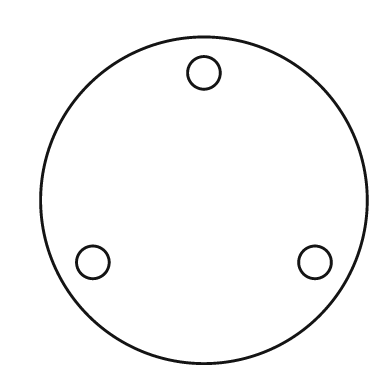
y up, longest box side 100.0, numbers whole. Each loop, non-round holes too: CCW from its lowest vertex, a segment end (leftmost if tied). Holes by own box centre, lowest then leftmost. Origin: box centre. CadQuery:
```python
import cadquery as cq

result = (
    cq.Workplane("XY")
    .moveTo(0.0, 0.0)
    .circle(50.0)
    .moveTo(-34.0, -19.0)
    .circle(5.0)
    .moveTo(34.0, -19.0)
    .circle(5.0)
    .moveTo(0.0, 39.0)
    .circle(5.0)
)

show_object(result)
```